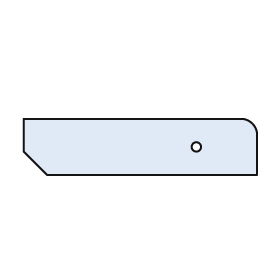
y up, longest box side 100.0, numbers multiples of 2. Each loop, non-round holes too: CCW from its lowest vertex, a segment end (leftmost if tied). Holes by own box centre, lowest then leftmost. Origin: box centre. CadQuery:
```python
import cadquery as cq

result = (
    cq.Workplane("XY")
    .moveTo(-40.0, -12.0)
    .lineTo(50.0, -12.0)
    .lineTo(50.0, 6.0)
    .threePointArc((48.0, 10.0), (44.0, 12.0))
    .lineTo(-50.0, 12.0)
    .lineTo(-50.0, -2.0)
    .close()
    .moveTo(24.0, 0.0)
    .circle(2.0)
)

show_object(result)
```